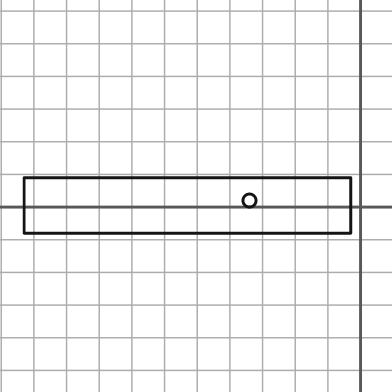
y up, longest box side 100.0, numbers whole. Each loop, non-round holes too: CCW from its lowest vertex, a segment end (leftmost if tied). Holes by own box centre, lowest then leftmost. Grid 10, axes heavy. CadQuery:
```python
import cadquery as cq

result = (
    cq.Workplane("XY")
    .moveTo(-103.0, -8.0)
    .lineTo(-3.0, -8.0)
    .lineTo(-3.0, 9.0)
    .lineTo(-103.0, 9.0)
    .close()
    .moveTo(-34.0, 2.0)
    .circle(2.0)
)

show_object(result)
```